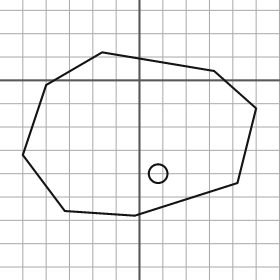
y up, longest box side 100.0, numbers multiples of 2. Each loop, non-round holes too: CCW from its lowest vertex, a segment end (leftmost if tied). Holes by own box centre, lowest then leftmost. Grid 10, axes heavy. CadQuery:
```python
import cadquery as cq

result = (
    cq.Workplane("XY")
    .moveTo(-2.0, -58.0)
    .lineTo(42.0, -44.0)
    .lineTo(50.0, -12.0)
    .lineTo(32.0, 4.0)
    .lineTo(-16.0, 12.0)
    .lineTo(-40.0, -2.0)
    .lineTo(-50.0, -32.0)
    .lineTo(-32.0, -56.0)
    .close()
    .moveTo(8.0, -40.0)
    .circle(4.0)
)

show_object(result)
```